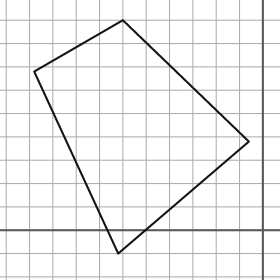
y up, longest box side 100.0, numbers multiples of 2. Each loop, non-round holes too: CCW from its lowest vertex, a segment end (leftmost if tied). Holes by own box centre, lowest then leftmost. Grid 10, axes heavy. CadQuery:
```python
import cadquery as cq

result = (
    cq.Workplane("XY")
    .moveTo(-62.0, -10.0)
    .lineTo(-6.0, 38.0)
    .lineTo(-60.0, 90.0)
    .lineTo(-98.0, 68.0)
    .close()
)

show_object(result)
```